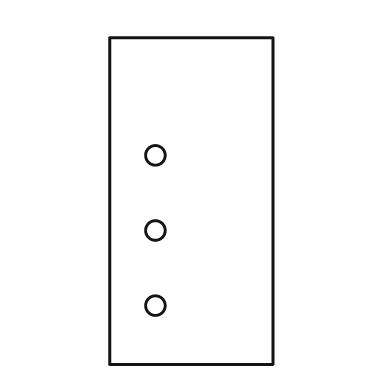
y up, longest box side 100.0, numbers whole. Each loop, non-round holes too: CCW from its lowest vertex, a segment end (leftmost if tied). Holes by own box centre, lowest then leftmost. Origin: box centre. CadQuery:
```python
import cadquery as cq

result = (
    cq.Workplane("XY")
    .moveTo(-25.0, -50.0)
    .lineTo(25.0, -50.0)
    .lineTo(25.0, 50.0)
    .lineTo(-25.0, 50.0)
    .close()
    .moveTo(-11.0, -32.0)
    .circle(3.0)
    .moveTo(-11.0, -9.0)
    .circle(3.0)
    .moveTo(-11.0, 14.0)
    .circle(3.0)
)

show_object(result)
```